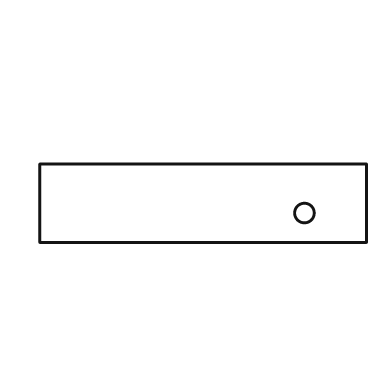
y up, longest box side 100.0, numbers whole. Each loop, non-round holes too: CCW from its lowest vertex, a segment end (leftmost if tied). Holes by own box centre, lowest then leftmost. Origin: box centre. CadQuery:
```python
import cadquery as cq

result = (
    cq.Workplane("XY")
    .moveTo(-50.0, -12.0)
    .lineTo(50.0, -12.0)
    .lineTo(50.0, 12.0)
    .lineTo(-50.0, 12.0)
    .close()
    .moveTo(31.0, -3.0)
    .circle(3.0)
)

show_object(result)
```